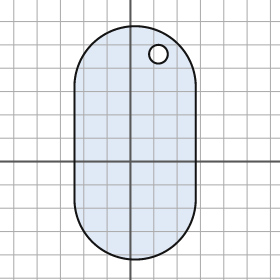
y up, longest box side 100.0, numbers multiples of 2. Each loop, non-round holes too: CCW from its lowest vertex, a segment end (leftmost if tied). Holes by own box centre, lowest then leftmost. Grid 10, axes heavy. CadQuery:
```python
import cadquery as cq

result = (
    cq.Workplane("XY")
    .moveTo(-24.0, -16.0)
    .threePointArc((2.0, -42.0), (28.0, -16.0))
    .lineTo(28.0, 32.0)
    .threePointArc((2.0, 58.0), (-24.0, 32.0))
    .close()
    .moveTo(12.0, 46.0)
    .circle(4.0)
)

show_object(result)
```